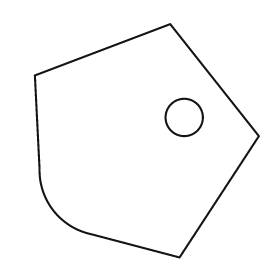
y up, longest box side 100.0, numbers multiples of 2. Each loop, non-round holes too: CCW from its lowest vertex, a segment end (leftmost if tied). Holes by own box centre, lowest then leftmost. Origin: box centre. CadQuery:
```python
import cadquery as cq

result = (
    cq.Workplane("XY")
    .moveTo(14.0, -50.0)
    .lineTo(48.0, 2.0)
    .lineTo(10.0, 50.0)
    .lineTo(-48.0, 28.0)
    .lineTo(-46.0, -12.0)
    .threePointArc((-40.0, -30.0), (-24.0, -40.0))
    .close()
    .moveTo(16.0, 10.0)
    .circle(8.0)
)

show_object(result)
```